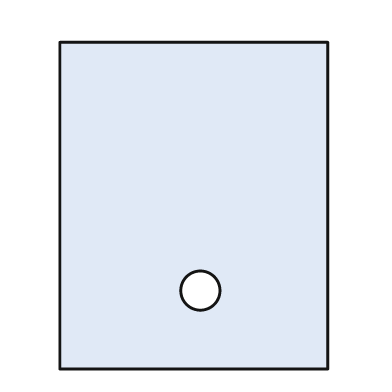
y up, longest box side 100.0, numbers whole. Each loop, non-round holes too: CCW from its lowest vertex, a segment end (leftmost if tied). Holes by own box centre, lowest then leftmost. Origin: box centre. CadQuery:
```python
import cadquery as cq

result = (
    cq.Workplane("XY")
    .moveTo(-41.0, -50.0)
    .lineTo(41.0, -50.0)
    .lineTo(41.0, 50.0)
    .lineTo(-41.0, 50.0)
    .close()
    .moveTo(2.0, -26.0)
    .circle(6.0)
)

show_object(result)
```